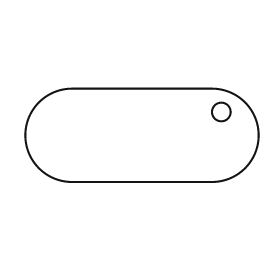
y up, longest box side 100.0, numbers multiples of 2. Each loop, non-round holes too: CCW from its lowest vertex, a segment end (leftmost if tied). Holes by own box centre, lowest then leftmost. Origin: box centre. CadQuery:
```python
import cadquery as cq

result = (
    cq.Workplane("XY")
    .moveTo(-30.0, -20.0)
    .lineTo(30.0, -20.0)
    .threePointArc((50.0, 0.0), (30.0, 20.0))
    .lineTo(-30.0, 20.0)
    .threePointArc((-50.0, 0.0), (-30.0, -20.0))
    .close()
    .moveTo(34.0, 10.0)
    .circle(4.0)
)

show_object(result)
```